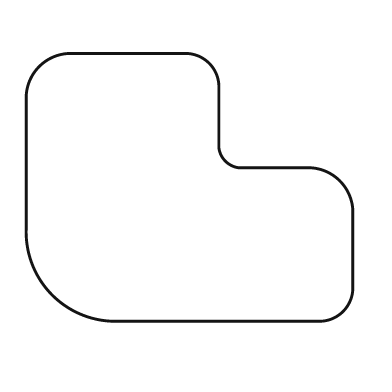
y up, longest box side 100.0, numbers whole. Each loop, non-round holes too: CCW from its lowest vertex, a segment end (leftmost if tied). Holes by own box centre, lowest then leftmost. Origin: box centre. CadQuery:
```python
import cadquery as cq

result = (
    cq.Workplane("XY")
    .moveTo(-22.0, -41.0)
    .lineTo(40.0, -41.0)
    .threePointArc((47.0, -38.0), (50.0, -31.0))
    .lineTo(50.0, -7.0)
    .threePointArc((46.0, 2.0), (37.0, 6.0))
    .lineTo(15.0, 6.0)
    .threePointArc((11.0, 8.0), (9.0, 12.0))
    .lineTo(9.0, 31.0)
    .threePointArc((6.0, 38.0), (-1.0, 41.0))
    .lineTo(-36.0, 41.0)
    .threePointArc((-46.0, 37.0), (-50.0, 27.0))
    .lineTo(-50.0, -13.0)
    .threePointArc((-42.0, -33.0), (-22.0, -41.0))
    .close()
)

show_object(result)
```